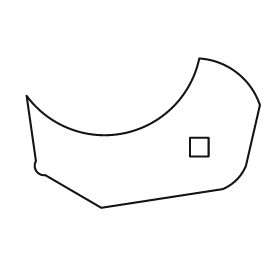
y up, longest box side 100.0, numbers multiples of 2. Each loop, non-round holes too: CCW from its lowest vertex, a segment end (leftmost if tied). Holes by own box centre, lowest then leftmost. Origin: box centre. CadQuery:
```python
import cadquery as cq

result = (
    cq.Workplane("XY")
    .moveTo(-18.0, -32.0)
    .lineTo(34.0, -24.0)
    .threePointArc((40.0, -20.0), (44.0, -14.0))
    .lineTo(50.0, 12.0)
    .threePointArc((40.0, 26.0), (24.0, 32.0))
    .threePointArc((-8.0, 0.0), (-50.0, 16.0))
    .lineTo(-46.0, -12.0)
    .threePointArc((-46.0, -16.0), (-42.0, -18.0))
    .close()
    .moveTo(20.0, -10.0)
    .lineTo(28.0, -10.0)
    .lineTo(28.0, -2.0)
    .lineTo(20.0, -2.0)
    .close()
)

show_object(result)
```